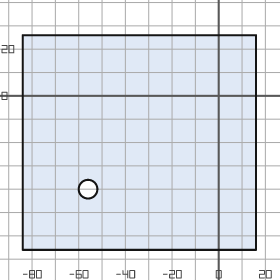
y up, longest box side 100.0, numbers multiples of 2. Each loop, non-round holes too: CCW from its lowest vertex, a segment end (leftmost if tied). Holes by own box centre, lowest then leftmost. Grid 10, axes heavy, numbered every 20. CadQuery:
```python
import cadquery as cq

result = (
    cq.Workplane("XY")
    .moveTo(-84.0, -66.0)
    .lineTo(16.0, -66.0)
    .lineTo(16.0, 26.0)
    .lineTo(-84.0, 26.0)
    .close()
    .moveTo(-56.0, -40.0)
    .circle(4.0)
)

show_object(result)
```